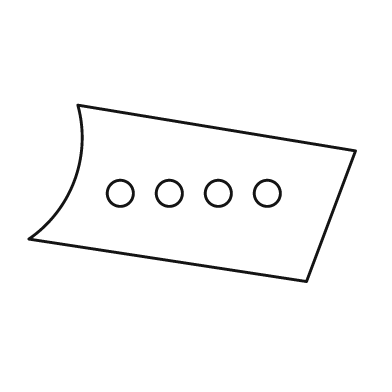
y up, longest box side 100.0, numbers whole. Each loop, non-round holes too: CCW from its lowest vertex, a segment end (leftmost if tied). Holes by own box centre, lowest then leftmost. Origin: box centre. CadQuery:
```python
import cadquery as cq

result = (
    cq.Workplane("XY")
    .moveTo(35.0, -27.0)
    .lineTo(50.0, 13.0)
    .lineTo(-35.0, 27.0)
    .threePointArc((-36.0, 4.0), (-50.0, -14.0))
    .close()
    .moveTo(-22.0, 0.0)
    .circle(4.0)
    .moveTo(-7.0, 0.0)
    .circle(4.0)
    .moveTo(8.0, 0.0)
    .circle(4.0)
    .moveTo(23.0, 0.0)
    .circle(4.0)
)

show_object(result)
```